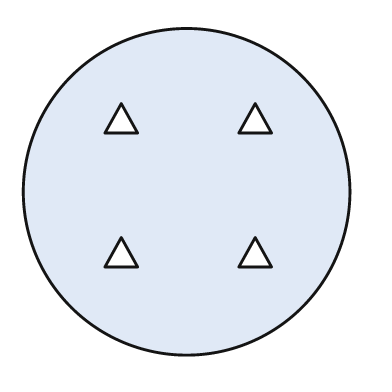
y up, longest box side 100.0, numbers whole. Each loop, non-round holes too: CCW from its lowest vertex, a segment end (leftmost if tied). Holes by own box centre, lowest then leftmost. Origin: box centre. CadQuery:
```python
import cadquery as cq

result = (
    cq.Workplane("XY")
    .moveTo(0.0, 0.0)
    .circle(50.0)
    .moveTo(-25.0, -23.0)
    .lineTo(-15.0, -23.0)
    .lineTo(-20.0, -14.0)
    .close()
    .moveTo(16.0, -23.0)
    .lineTo(26.0, -23.0)
    .lineTo(21.0, -14.0)
    .close()
    .moveTo(-25.0, 18.0)
    .lineTo(-15.0, 18.0)
    .lineTo(-20.0, 27.0)
    .close()
    .moveTo(16.0, 18.0)
    .lineTo(26.0, 18.0)
    .lineTo(21.0, 27.0)
    .close()
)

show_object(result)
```